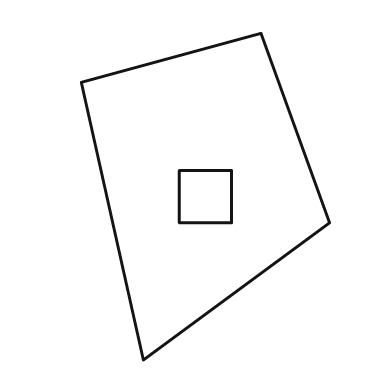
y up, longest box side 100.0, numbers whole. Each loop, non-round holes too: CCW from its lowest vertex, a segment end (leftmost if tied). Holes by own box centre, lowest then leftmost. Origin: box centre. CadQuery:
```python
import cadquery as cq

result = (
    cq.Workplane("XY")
    .moveTo(-19.0, -50.0)
    .lineTo(38.0, -8.0)
    .lineTo(17.0, 50.0)
    .lineTo(-38.0, 35.0)
    .close()
    .moveTo(-8.0, -8.0)
    .lineTo(8.0, -8.0)
    .lineTo(8.0, 8.0)
    .lineTo(-8.0, 8.0)
    .close()
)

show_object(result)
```